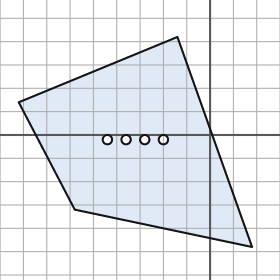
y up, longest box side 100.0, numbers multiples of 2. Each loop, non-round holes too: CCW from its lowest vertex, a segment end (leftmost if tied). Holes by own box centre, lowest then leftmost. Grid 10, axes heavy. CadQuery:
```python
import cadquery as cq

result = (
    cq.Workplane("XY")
    .moveTo(18.0, -48.0)
    .lineTo(-14.0, 42.0)
    .lineTo(-82.0, 14.0)
    .lineTo(-58.0, -32.0)
    .close()
    .moveTo(-44.0, -2.0)
    .circle(2.0)
    .moveTo(-36.0, -2.0)
    .circle(2.0)
    .moveTo(-28.0, -2.0)
    .circle(2.0)
    .moveTo(-20.0, -2.0)
    .circle(2.0)
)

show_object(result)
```